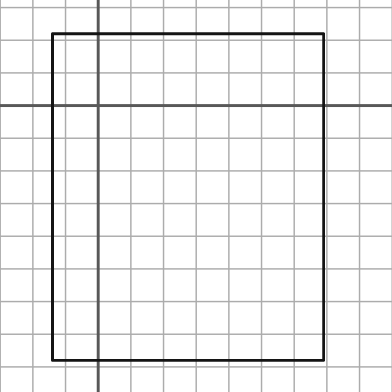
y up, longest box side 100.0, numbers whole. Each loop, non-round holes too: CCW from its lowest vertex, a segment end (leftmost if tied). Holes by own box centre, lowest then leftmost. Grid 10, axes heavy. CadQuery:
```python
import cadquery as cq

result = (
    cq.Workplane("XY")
    .moveTo(-14.0, -78.0)
    .lineTo(69.0, -78.0)
    .lineTo(69.0, 22.0)
    .lineTo(-14.0, 22.0)
    .close()
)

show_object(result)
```